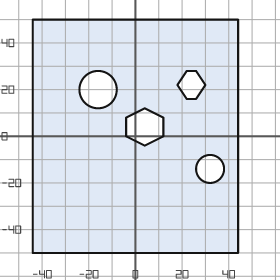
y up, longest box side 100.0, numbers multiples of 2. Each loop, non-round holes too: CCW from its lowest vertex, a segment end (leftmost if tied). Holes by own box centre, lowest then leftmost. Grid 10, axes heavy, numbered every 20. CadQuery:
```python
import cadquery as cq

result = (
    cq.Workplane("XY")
    .moveTo(-44.0, -50.0)
    .lineTo(44.0, -50.0)
    .lineTo(44.0, 50.0)
    .lineTo(-44.0, 50.0)
    .close()
    .moveTo(32.0, -14.0)
    .circle(6.0)
    .moveTo(4.0, -4.0)
    .lineTo(12.0, 0.0)
    .lineTo(12.0, 8.0)
    .lineTo(4.0, 12.0)
    .lineTo(-4.0, 8.0)
    .lineTo(-4.0, 0.0)
    .close()
    .moveTo(-16.0, 20.0)
    .circle(8.0)
    .moveTo(22.0, 16.0)
    .lineTo(26.0, 16.0)
    .lineTo(30.0, 22.0)
    .lineTo(26.0, 28.0)
    .lineTo(22.0, 28.0)
    .lineTo(18.0, 22.0)
    .close()
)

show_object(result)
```